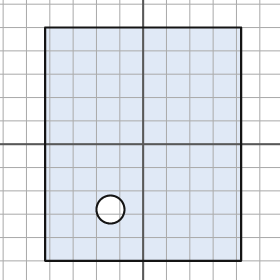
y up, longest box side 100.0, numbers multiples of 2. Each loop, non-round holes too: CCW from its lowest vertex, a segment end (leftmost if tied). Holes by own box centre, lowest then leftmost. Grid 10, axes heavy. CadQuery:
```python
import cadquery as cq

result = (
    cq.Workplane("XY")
    .moveTo(-42.0, -50.0)
    .lineTo(42.0, -50.0)
    .lineTo(42.0, 50.0)
    .lineTo(-42.0, 50.0)
    .close()
    .moveTo(-14.0, -28.0)
    .circle(6.0)
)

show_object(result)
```